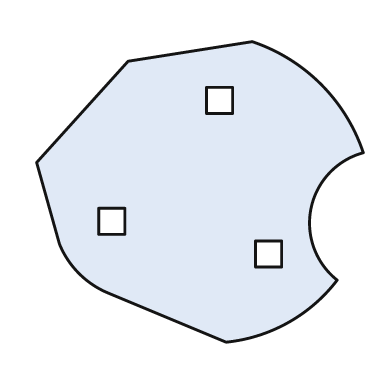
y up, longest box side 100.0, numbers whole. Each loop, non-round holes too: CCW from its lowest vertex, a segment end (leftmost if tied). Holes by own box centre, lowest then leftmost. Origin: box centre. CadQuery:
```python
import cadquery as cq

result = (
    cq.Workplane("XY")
    .moveTo(8.0, -46.0)
    .threePointArc((27.0, -40.0), (42.0, -27.0))
    .threePointArc((34.0, -5.0), (50.0, 12.0))
    .threePointArc((37.0, 33.0), (16.0, 46.0))
    .lineTo(-22.0, 40.0)
    .lineTo(-50.0, 9.0)
    .lineTo(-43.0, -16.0)
    .threePointArc((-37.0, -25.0), (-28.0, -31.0))
    .close()
    .moveTo(17.0, -23.0)
    .lineTo(25.0, -23.0)
    .lineTo(25.0, -15.0)
    .lineTo(17.0, -15.0)
    .close()
    .moveTo(-31.0, -13.0)
    .lineTo(-23.0, -13.0)
    .lineTo(-23.0, -5.0)
    .lineTo(-31.0, -5.0)
    .close()
    .moveTo(2.0, 24.0)
    .lineTo(10.0, 24.0)
    .lineTo(10.0, 32.0)
    .lineTo(2.0, 32.0)
    .close()
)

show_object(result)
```